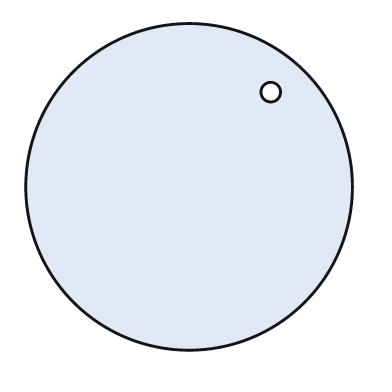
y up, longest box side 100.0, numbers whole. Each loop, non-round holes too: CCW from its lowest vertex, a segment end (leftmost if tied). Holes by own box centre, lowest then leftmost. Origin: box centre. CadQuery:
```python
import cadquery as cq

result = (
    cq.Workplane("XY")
    .moveTo(0.0, 0.0)
    .circle(50.0)
    .moveTo(25.0, 29.0)
    .circle(3.0)
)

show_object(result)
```